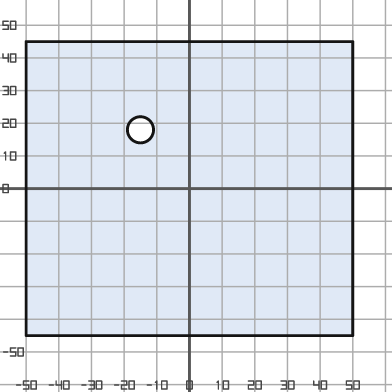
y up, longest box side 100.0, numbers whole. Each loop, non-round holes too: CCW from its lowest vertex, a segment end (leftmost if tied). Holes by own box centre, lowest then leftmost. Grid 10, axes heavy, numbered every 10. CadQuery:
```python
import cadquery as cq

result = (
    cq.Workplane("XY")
    .moveTo(-50.0, -45.0)
    .lineTo(50.0, -45.0)
    .lineTo(50.0, 45.0)
    .lineTo(-50.0, 45.0)
    .close()
    .moveTo(-15.0, 18.0)
    .circle(4.0)
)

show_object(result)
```